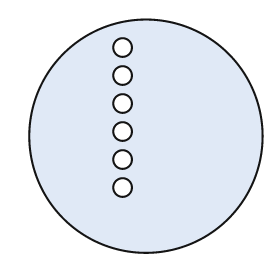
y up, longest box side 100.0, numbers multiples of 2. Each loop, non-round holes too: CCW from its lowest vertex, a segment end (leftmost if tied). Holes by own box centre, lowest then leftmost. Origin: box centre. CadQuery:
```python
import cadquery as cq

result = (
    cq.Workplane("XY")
    .moveTo(0.0, 0.0)
    .circle(50.0)
    .moveTo(-10.0, -22.0)
    .circle(4.0)
    .moveTo(-10.0, -10.0)
    .circle(4.0)
    .moveTo(-10.0, 2.0)
    .circle(4.0)
    .moveTo(-10.0, 14.0)
    .circle(4.0)
    .moveTo(-10.0, 26.0)
    .circle(4.0)
    .moveTo(-10.0, 38.0)
    .circle(4.0)
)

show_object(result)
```